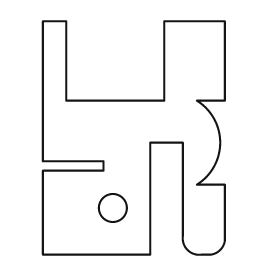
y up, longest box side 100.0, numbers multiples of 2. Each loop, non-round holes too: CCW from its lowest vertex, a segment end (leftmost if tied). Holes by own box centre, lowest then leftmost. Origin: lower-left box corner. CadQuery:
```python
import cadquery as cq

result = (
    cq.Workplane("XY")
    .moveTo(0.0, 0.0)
    .lineTo(46.0, 0.0)
    .lineTo(46.0, 48.0)
    .lineTo(60.0, 48.0)
    .lineTo(60.0, 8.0)
    .threePointArc((62.0, 2.0), (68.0, 0.0))
    .lineTo(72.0, 0.0)
    .threePointArc((76.0, 2.0), (78.0, 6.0))
    .lineTo(78.0, 30.0)
    .lineTo(66.0, 30.0)
    .threePointArc((76.0, 48.0), (66.0, 66.0))
    .lineTo(78.0, 66.0)
    .lineTo(78.0, 100.0)
    .lineTo(52.0, 100.0)
    .lineTo(52.0, 66.0)
    .lineTo(10.0, 66.0)
    .lineTo(10.0, 100.0)
    .lineTo(0.0, 100.0)
    .lineTo(0.0, 40.0)
    .lineTo(26.0, 40.0)
    .lineTo(26.0, 36.0)
    .lineTo(0.0, 36.0)
    .close()
    .moveTo(30.0, 20.0)
    .circle(6.0)
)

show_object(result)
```